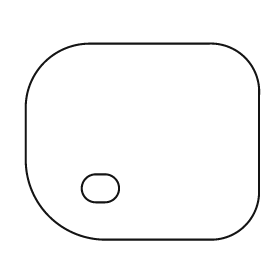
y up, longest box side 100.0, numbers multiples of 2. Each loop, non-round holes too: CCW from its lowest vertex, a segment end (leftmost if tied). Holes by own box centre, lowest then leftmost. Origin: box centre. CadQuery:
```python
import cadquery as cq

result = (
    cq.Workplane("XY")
    .moveTo(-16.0, -42.0)
    .lineTo(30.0, -42.0)
    .threePointArc((44.0, -36.0), (50.0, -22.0))
    .lineTo(50.0, 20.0)
    .threePointArc((44.0, 36.0), (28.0, 42.0))
    .lineTo(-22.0, 42.0)
    .threePointArc((-42.0, 34.0), (-50.0, 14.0))
    .lineTo(-50.0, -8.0)
    .threePointArc((-40.0, -32.0), (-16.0, -42.0))
    .close()
    .moveTo(-20.0, -26.0)
    .lineTo(-16.0, -26.0)
    .threePointArc((-10.0, -20.0), (-16.0, -14.0))
    .lineTo(-20.0, -14.0)
    .threePointArc((-26.0, -20.0), (-20.0, -26.0))
    .close()
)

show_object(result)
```